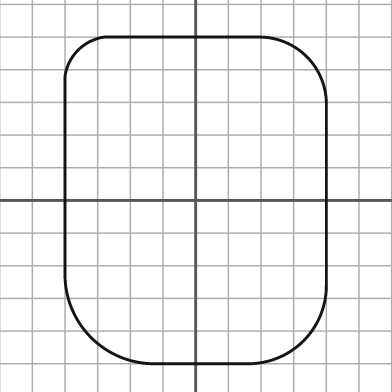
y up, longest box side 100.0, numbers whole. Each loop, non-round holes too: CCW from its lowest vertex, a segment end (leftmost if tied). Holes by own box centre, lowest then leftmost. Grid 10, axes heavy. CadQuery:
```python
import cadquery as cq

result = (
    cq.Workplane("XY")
    .moveTo(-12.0, -50.0)
    .lineTo(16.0, -50.0)
    .threePointArc((33.0, -43.0), (40.0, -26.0))
    .lineTo(40.0, 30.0)
    .threePointArc((34.0, 44.0), (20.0, 50.0))
    .lineTo(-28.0, 50.0)
    .threePointArc((-36.0, 46.0), (-40.0, 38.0))
    .lineTo(-40.0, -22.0)
    .threePointArc((-32.0, -42.0), (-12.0, -50.0))
    .close()
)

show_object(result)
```